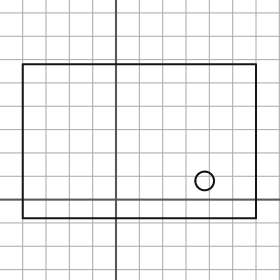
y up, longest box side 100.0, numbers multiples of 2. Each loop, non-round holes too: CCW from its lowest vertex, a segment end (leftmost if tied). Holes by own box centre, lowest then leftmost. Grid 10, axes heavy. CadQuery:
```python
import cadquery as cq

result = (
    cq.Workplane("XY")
    .moveTo(-40.0, -8.0)
    .lineTo(60.0, -8.0)
    .lineTo(60.0, 58.0)
    .lineTo(-40.0, 58.0)
    .close()
    .moveTo(38.0, 8.0)
    .circle(4.0)
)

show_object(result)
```